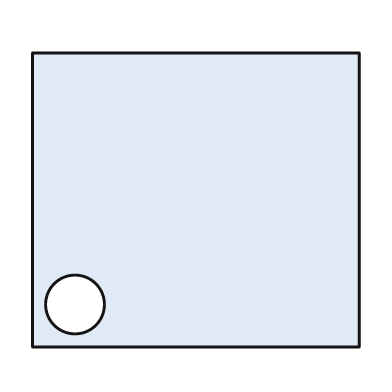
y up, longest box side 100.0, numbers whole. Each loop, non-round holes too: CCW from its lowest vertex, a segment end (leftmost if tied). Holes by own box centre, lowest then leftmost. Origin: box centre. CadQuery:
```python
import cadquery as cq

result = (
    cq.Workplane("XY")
    .moveTo(-50.0, -45.0)
    .lineTo(50.0, -45.0)
    .lineTo(50.0, 45.0)
    .lineTo(-50.0, 45.0)
    .close()
    .moveTo(-37.0, -32.0)
    .circle(9.0)
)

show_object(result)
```